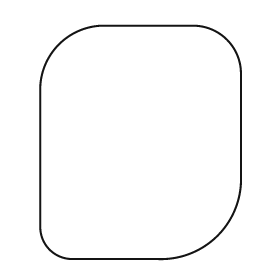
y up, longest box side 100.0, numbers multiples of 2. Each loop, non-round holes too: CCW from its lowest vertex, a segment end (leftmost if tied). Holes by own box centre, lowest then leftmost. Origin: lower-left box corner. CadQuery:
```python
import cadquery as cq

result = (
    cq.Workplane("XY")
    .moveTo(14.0, 0.0)
    .lineTo(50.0, 0.0)
    .threePointArc((76.0, 10.0), (86.0, 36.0))
    .lineTo(86.0, 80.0)
    .threePointArc((80.0, 94.0), (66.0, 100.0))
    .lineTo(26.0, 100.0)
    .threePointArc((8.0, 92.0), (0.0, 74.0))
    .lineTo(0.0, 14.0)
    .threePointArc((4.0, 4.0), (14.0, 0.0))
    .close()
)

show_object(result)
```